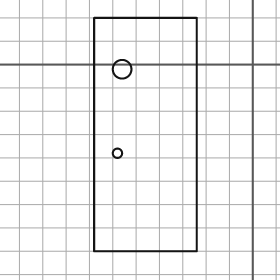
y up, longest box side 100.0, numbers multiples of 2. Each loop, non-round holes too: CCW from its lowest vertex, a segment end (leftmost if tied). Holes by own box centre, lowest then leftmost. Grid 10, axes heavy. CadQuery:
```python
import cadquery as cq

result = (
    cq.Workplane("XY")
    .moveTo(-68.0, -80.0)
    .lineTo(-24.0, -80.0)
    .lineTo(-24.0, 20.0)
    .lineTo(-68.0, 20.0)
    .close()
    .moveTo(-58.0, -38.0)
    .circle(2.0)
    .moveTo(-56.0, -2.0)
    .circle(4.0)
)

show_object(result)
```